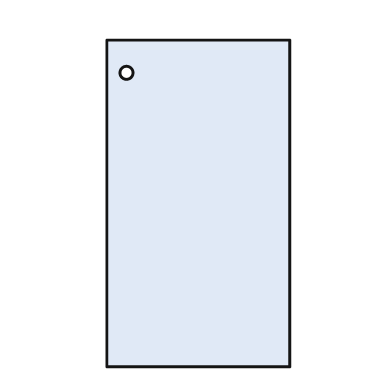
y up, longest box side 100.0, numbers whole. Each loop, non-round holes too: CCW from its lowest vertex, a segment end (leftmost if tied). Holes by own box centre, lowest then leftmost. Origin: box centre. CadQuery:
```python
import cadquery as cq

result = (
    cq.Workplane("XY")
    .moveTo(-28.0, -50.0)
    .lineTo(28.0, -50.0)
    .lineTo(28.0, 50.0)
    .lineTo(-28.0, 50.0)
    .close()
    .moveTo(-22.0, 40.0)
    .circle(2.0)
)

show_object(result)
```